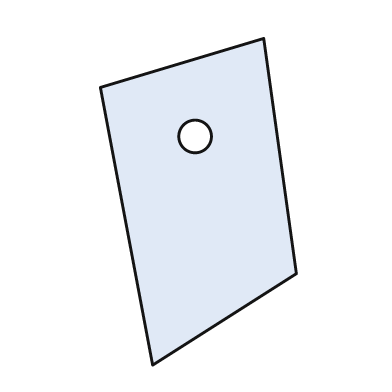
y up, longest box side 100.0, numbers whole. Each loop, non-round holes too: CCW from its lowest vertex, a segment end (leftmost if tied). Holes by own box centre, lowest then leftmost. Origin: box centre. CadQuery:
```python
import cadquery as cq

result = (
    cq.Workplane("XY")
    .moveTo(-14.0, -50.0)
    .lineTo(30.0, -22.0)
    .lineTo(20.0, 50.0)
    .lineTo(-30.0, 35.0)
    .close()
    .moveTo(-1.0, 20.0)
    .circle(5.0)
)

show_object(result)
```